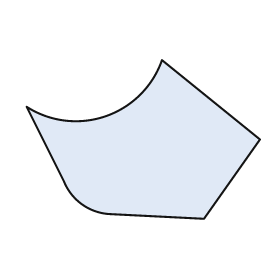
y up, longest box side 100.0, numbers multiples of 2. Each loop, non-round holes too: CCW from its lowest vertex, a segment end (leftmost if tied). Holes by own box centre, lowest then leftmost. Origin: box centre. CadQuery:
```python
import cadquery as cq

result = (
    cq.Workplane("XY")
    .moveTo(26.0, -34.0)
    .lineTo(50.0, 0.0)
    .lineTo(8.0, 34.0)
    .threePointArc((-16.0, 10.0), (-50.0, 14.0))
    .lineTo(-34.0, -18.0)
    .threePointArc((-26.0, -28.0), (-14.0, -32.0))
    .close()
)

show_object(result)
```